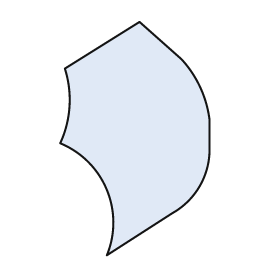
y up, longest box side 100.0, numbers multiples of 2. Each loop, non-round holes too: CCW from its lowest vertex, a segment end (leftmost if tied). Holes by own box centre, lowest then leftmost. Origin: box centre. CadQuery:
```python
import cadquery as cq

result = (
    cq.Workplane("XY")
    .moveTo(-12.0, -50.0)
    .lineTo(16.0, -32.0)
    .threePointArc((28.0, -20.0), (32.0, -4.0))
    .lineTo(32.0, 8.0)
    .threePointArc((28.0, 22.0), (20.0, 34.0))
    .lineTo(2.0, 50.0)
    .lineTo(-30.0, 30.0)
    .threePointArc((-28.0, 14.0), (-32.0, -2.0))
    .threePointArc((-12.0, -22.0), (-12.0, -50.0))
    .close()
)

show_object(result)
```